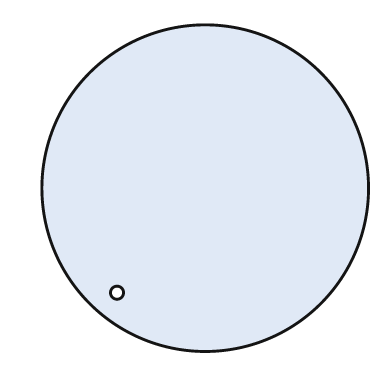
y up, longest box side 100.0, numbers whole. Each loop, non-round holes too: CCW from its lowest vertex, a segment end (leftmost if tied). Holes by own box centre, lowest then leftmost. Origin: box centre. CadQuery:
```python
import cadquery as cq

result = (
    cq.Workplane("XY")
    .moveTo(0.0, 0.0)
    .circle(50.0)
    .moveTo(-27.0, -32.0)
    .circle(2.0)
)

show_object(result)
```